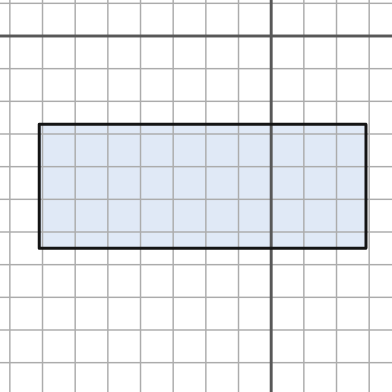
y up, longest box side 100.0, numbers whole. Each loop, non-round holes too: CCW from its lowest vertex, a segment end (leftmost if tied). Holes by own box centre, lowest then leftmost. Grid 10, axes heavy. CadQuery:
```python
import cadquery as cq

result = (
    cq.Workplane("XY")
    .moveTo(-71.0, -65.0)
    .lineTo(29.0, -65.0)
    .lineTo(29.0, -27.0)
    .lineTo(-71.0, -27.0)
    .close()
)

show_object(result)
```